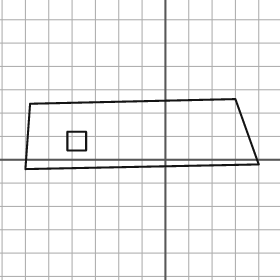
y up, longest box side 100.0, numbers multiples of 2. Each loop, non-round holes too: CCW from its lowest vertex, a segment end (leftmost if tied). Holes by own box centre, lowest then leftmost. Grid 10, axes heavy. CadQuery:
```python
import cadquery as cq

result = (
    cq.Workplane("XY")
    .moveTo(-60.0, -4.0)
    .lineTo(40.0, -2.0)
    .lineTo(30.0, 26.0)
    .lineTo(-58.0, 24.0)
    .close()
    .moveTo(-42.0, 4.0)
    .lineTo(-34.0, 4.0)
    .lineTo(-34.0, 12.0)
    .lineTo(-42.0, 12.0)
    .close()
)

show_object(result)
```